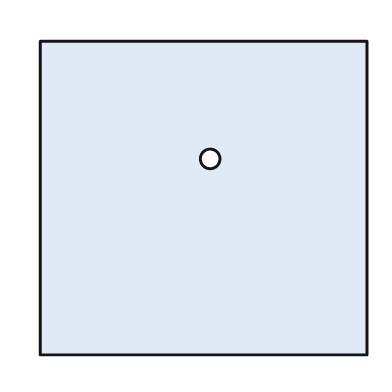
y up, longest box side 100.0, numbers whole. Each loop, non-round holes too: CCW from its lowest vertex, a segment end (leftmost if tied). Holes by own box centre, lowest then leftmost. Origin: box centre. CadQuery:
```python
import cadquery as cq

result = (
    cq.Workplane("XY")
    .moveTo(-50.0, -48.0)
    .lineTo(50.0, -48.0)
    .lineTo(50.0, 48.0)
    .lineTo(-50.0, 48.0)
    .close()
    .moveTo(2.0, 12.0)
    .circle(3.0)
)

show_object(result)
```